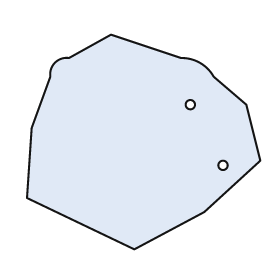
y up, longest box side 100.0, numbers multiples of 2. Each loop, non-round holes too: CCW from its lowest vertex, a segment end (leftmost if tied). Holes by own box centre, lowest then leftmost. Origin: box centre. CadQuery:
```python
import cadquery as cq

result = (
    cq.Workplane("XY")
    .moveTo(-4.0, -46.0)
    .lineTo(26.0, -30.0)
    .lineTo(50.0, -8.0)
    .lineTo(44.0, 16.0)
    .lineTo(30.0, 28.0)
    .threePointArc((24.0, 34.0), (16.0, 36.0))
    .lineTo(-14.0, 46.0)
    .lineTo(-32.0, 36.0)
    .threePointArc((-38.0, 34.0), (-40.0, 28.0))
    .lineTo(-48.0, 6.0)
    .lineTo(-50.0, -24.0)
    .close()
    .moveTo(34.0, -10.0)
    .circle(2.0)
    .moveTo(20.0, 16.0)
    .circle(2.0)
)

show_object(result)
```